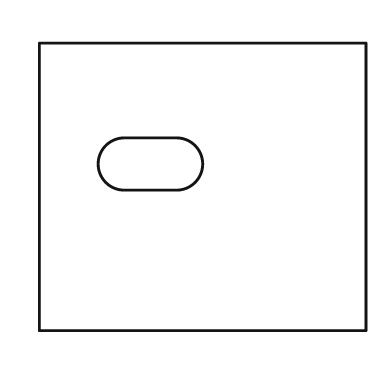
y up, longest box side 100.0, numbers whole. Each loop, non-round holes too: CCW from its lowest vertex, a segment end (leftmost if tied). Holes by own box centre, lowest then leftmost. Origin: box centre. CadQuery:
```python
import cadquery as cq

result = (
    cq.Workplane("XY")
    .moveTo(-50.0, -44.0)
    .lineTo(50.0, -44.0)
    .lineTo(50.0, 44.0)
    .lineTo(-50.0, 44.0)
    .close()
    .moveTo(-24.0, -1.0)
    .lineTo(-8.0, -1.0)
    .threePointArc((0.0, 7.0), (-8.0, 15.0))
    .lineTo(-24.0, 15.0)
    .threePointArc((-32.0, 7.0), (-24.0, -1.0))
    .close()
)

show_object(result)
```